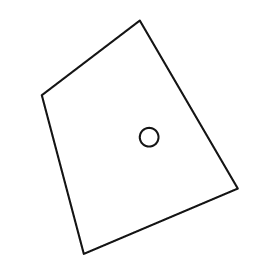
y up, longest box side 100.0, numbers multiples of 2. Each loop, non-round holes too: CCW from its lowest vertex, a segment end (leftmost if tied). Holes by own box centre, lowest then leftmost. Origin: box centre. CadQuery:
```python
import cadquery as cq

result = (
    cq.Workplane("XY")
    .moveTo(-24.0, -50.0)
    .lineTo(42.0, -22.0)
    .lineTo(0.0, 50.0)
    .lineTo(-42.0, 18.0)
    .close()
    .moveTo(4.0, 0.0)
    .circle(4.0)
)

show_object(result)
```